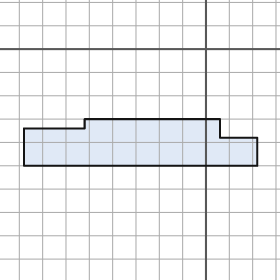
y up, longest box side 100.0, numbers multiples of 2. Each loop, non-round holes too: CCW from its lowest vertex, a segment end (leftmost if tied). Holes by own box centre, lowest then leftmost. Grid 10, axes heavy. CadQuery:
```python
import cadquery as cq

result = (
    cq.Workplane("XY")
    .moveTo(-78.0, -50.0)
    .lineTo(22.0, -50.0)
    .lineTo(22.0, -38.0)
    .lineTo(6.0, -38.0)
    .lineTo(6.0, -30.0)
    .lineTo(-52.0, -30.0)
    .lineTo(-52.0, -34.0)
    .lineTo(-78.0, -34.0)
    .close()
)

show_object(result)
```